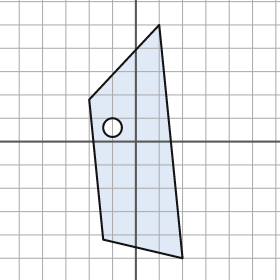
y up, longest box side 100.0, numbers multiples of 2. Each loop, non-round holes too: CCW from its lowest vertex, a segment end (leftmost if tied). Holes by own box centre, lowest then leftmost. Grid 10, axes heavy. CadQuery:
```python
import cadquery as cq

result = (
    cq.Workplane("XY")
    .moveTo(20.0, -50.0)
    .lineTo(10.0, 50.0)
    .lineTo(-20.0, 18.0)
    .lineTo(-14.0, -42.0)
    .close()
    .moveTo(-10.0, 6.0)
    .circle(4.0)
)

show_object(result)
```